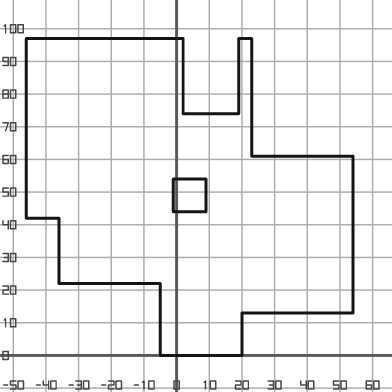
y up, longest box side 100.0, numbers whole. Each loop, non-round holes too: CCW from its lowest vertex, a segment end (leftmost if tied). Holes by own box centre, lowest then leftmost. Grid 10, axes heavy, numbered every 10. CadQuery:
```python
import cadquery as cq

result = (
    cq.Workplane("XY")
    .moveTo(-5.0, 0.0)
    .lineTo(20.0, 0.0)
    .lineTo(20.0, 13.0)
    .lineTo(54.0, 13.0)
    .lineTo(54.0, 61.0)
    .lineTo(23.0, 61.0)
    .lineTo(23.0, 97.0)
    .lineTo(19.0, 97.0)
    .lineTo(19.0, 74.0)
    .lineTo(2.0, 74.0)
    .lineTo(2.0, 97.0)
    .lineTo(-46.0, 97.0)
    .lineTo(-46.0, 42.0)
    .lineTo(-36.0, 42.0)
    .lineTo(-36.0, 22.0)
    .lineTo(-5.0, 22.0)
    .close()
    .moveTo(-1.0, 44.0)
    .lineTo(9.0, 44.0)
    .lineTo(9.0, 54.0)
    .lineTo(-1.0, 54.0)
    .close()
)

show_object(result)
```